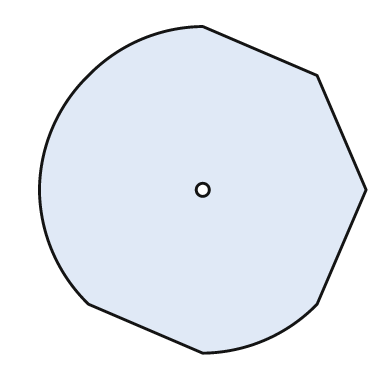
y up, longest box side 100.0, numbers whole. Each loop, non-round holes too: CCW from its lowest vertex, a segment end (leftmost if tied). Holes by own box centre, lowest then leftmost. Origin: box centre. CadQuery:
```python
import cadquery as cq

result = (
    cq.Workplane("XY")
    .moveTo(0.0, -50.0)
    .threePointArc((19.0, -46.0), (35.0, -35.0))
    .lineTo(50.0, 0.0)
    .lineTo(35.0, 35.0)
    .lineTo(0.0, 50.0)
    .threePointArc((-19.0, 46.0), (-35.0, 35.0))
    .threePointArc((-46.0, 19.0), (-50.0, 0.0))
    .threePointArc((-46.0, -19.0), (-35.0, -35.0))
    .close()
    .moveTo(0.0, 0.0)
    .circle(2.0)
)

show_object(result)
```